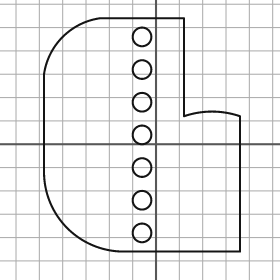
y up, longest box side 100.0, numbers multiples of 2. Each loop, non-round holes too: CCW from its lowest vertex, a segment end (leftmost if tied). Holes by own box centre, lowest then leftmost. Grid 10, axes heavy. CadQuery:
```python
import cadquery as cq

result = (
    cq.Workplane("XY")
    .moveTo(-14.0, -46.0)
    .lineTo(36.0, -46.0)
    .lineTo(36.0, 12.0)
    .threePointArc((24.0, 14.0), (12.0, 12.0))
    .lineTo(12.0, 54.0)
    .lineTo(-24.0, 54.0)
    .threePointArc((-40.0, 46.0), (-48.0, 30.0))
    .lineTo(-48.0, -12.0)
    .threePointArc((-38.0, -36.0), (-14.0, -46.0))
    .close()
    .moveTo(-6.0, -38.0)
    .circle(4.0)
    .moveTo(-6.0, -24.0)
    .circle(4.0)
    .moveTo(-6.0, -10.0)
    .circle(4.0)
    .moveTo(-6.0, 4.0)
    .circle(4.0)
    .moveTo(-6.0, 18.0)
    .circle(4.0)
    .moveTo(-6.0, 32.0)
    .circle(4.0)
    .moveTo(-6.0, 46.0)
    .circle(4.0)
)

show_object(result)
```